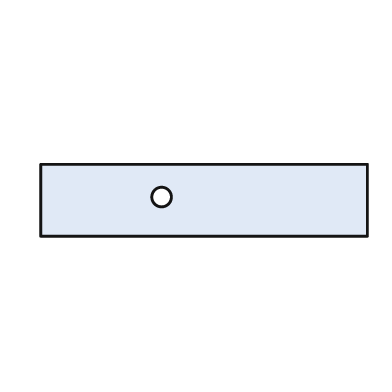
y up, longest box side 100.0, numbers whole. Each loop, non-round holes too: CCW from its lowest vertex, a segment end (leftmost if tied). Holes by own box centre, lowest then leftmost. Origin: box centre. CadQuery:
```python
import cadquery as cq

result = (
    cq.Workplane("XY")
    .moveTo(-50.0, -11.0)
    .lineTo(50.0, -11.0)
    .lineTo(50.0, 11.0)
    .lineTo(-50.0, 11.0)
    .close()
    .moveTo(-13.0, 1.0)
    .circle(3.0)
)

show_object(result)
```